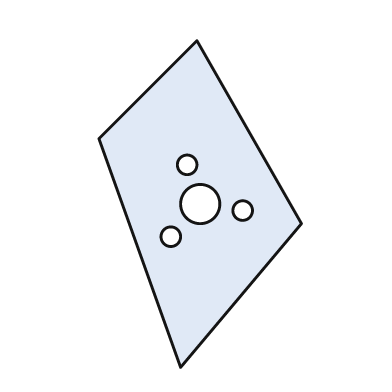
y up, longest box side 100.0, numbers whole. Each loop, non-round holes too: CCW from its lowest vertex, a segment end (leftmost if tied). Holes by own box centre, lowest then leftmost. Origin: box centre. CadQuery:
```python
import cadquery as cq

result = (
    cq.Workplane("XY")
    .moveTo(-6.0, -50.0)
    .lineTo(31.0, -6.0)
    .lineTo(-1.0, 50.0)
    .lineTo(-31.0, 20.0)
    .close()
    .moveTo(-9.0, -10.0)
    .circle(3.0)
    .moveTo(13.0, -2.0)
    .circle(3.0)
    .moveTo(0.0, 0.0)
    .circle(6.0)
    .moveTo(-4.0, 12.0)
    .circle(3.0)
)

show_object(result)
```